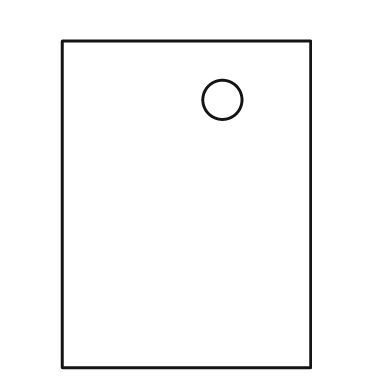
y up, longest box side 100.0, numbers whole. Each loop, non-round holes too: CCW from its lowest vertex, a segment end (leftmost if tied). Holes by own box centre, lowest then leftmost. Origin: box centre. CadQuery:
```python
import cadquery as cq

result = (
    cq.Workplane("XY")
    .moveTo(-38.0, -50.0)
    .lineTo(38.0, -50.0)
    .lineTo(38.0, 50.0)
    .lineTo(-38.0, 50.0)
    .close()
    .moveTo(11.0, 32.0)
    .circle(6.0)
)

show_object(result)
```